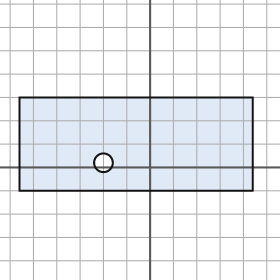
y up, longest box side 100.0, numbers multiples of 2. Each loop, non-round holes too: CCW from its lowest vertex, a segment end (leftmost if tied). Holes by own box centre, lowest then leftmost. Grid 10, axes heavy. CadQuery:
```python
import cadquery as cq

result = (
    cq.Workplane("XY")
    .moveTo(-56.0, -10.0)
    .lineTo(44.0, -10.0)
    .lineTo(44.0, 30.0)
    .lineTo(-56.0, 30.0)
    .close()
    .moveTo(-20.0, 2.0)
    .circle(4.0)
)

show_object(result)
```